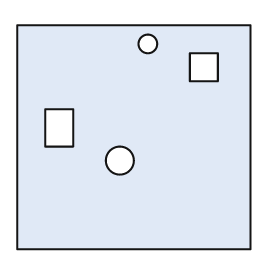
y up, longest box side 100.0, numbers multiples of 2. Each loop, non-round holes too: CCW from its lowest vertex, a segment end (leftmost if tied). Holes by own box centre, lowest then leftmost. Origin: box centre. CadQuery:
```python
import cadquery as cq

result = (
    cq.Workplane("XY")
    .moveTo(-50.0, -48.0)
    .lineTo(50.0, -48.0)
    .lineTo(50.0, 48.0)
    .lineTo(-50.0, 48.0)
    .close()
    .moveTo(-6.0, -10.0)
    .circle(6.0)
    .moveTo(-38.0, -4.0)
    .lineTo(-26.0, -4.0)
    .lineTo(-26.0, 12.0)
    .lineTo(-38.0, 12.0)
    .close()
    .moveTo(24.0, 24.0)
    .lineTo(36.0, 24.0)
    .lineTo(36.0, 36.0)
    .lineTo(24.0, 36.0)
    .close()
    .moveTo(6.0, 40.0)
    .circle(4.0)
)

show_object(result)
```